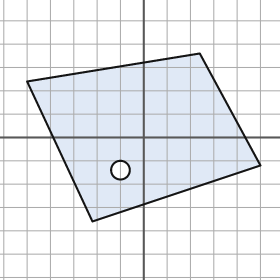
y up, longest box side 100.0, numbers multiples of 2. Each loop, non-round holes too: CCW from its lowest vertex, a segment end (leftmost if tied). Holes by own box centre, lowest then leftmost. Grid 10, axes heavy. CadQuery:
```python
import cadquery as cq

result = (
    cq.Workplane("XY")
    .moveTo(-22.0, -36.0)
    .lineTo(50.0, -12.0)
    .lineTo(24.0, 36.0)
    .lineTo(-50.0, 24.0)
    .close()
    .moveTo(-10.0, -14.0)
    .circle(4.0)
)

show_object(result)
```